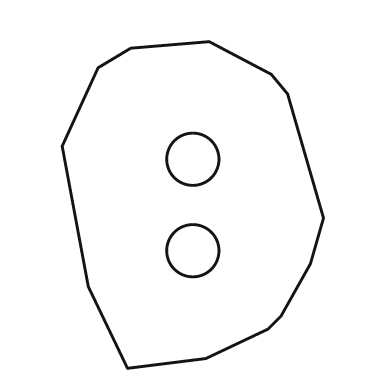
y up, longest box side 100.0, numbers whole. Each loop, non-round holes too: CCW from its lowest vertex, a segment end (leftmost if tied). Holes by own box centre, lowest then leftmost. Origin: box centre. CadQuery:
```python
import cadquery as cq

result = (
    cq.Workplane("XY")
    .moveTo(-20.0, -50.0)
    .lineTo(4.0, -47.0)
    .lineTo(23.0, -38.0)
    .lineTo(27.0, -34.0)
    .lineTo(36.0, -18.0)
    .lineTo(40.0, -4.0)
    .lineTo(29.0, 34.0)
    .lineTo(24.0, 40.0)
    .lineTo(5.0, 50.0)
    .lineTo(-19.0, 48.0)
    .lineTo(-29.0, 42.0)
    .lineTo(-40.0, 18.0)
    .lineTo(-32.0, -25.0)
    .close()
    .moveTo(0.0, -14.0)
    .circle(8.0)
    .moveTo(0.0, 14.0)
    .circle(8.0)
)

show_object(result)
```